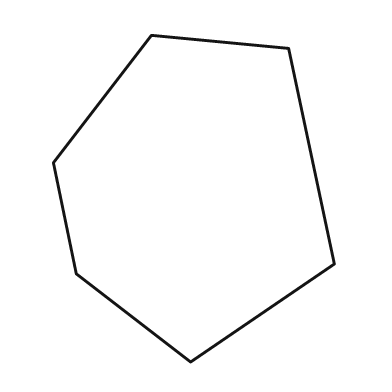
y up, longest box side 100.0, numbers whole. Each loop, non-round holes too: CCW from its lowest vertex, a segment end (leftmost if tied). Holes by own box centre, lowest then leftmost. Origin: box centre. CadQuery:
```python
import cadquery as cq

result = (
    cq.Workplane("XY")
    .moveTo(-1.0, -50.0)
    .lineTo(43.0, -20.0)
    .lineTo(29.0, 46.0)
    .lineTo(-13.0, 50.0)
    .lineTo(-43.0, 11.0)
    .lineTo(-36.0, -23.0)
    .close()
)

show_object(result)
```